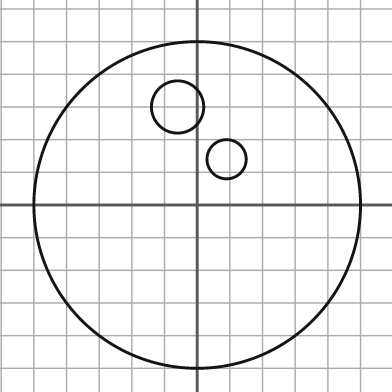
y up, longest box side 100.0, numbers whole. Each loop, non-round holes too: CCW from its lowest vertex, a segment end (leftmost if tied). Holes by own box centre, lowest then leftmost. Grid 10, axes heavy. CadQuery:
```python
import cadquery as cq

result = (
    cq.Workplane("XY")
    .moveTo(0.0, 0.0)
    .circle(50.0)
    .moveTo(9.0, 14.0)
    .circle(6.0)
    .moveTo(-6.0, 30.0)
    .circle(8.0)
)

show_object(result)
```